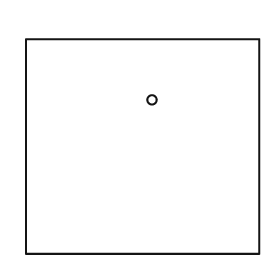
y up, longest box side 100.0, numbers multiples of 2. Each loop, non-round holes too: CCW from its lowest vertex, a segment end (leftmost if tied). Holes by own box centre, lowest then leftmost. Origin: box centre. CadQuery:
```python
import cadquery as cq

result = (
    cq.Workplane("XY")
    .moveTo(-50.0, -46.0)
    .lineTo(50.0, -46.0)
    .lineTo(50.0, 46.0)
    .lineTo(-50.0, 46.0)
    .close()
    .moveTo(4.0, 20.0)
    .circle(2.0)
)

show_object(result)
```